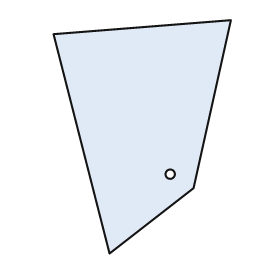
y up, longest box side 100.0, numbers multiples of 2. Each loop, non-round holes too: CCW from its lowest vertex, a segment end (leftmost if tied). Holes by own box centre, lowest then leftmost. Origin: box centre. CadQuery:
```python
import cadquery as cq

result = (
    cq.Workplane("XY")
    .moveTo(-14.0, -50.0)
    .lineTo(22.0, -22.0)
    .lineTo(38.0, 50.0)
    .lineTo(-38.0, 44.0)
    .close()
    .moveTo(12.0, -16.0)
    .circle(2.0)
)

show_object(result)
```